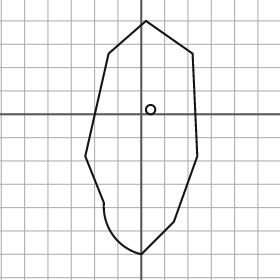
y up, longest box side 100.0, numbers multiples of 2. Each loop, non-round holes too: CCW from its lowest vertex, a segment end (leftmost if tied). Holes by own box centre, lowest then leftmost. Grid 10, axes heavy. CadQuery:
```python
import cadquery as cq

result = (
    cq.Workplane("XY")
    .moveTo(0.0, -60.0)
    .lineTo(14.0, -46.0)
    .lineTo(24.0, -18.0)
    .lineTo(22.0, 26.0)
    .lineTo(2.0, 40.0)
    .lineTo(-14.0, 26.0)
    .lineTo(-24.0, -18.0)
    .lineTo(-16.0, -38.0)
    .threePointArc((-12.0, -52.0), (0.0, -60.0))
    .close()
    .moveTo(4.0, 2.0)
    .circle(2.0)
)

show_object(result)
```